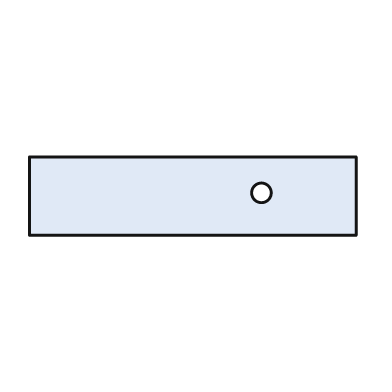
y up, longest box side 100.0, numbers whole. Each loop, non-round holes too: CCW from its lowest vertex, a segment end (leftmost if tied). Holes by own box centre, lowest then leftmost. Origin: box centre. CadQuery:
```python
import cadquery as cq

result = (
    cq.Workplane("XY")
    .moveTo(-50.0, -12.0)
    .lineTo(50.0, -12.0)
    .lineTo(50.0, 12.0)
    .lineTo(-50.0, 12.0)
    .close()
    .moveTo(21.0, 1.0)
    .circle(3.0)
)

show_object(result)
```